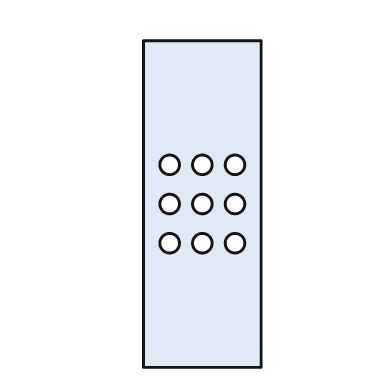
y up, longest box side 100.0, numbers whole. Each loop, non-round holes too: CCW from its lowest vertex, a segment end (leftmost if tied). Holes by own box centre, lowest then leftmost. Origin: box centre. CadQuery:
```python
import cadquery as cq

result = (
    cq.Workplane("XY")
    .moveTo(-18.0, -50.0)
    .lineTo(18.0, -50.0)
    .lineTo(18.0, 50.0)
    .lineTo(-18.0, 50.0)
    .close()
    .moveTo(-10.0, -12.0)
    .circle(3.0)
    .moveTo(0.0, -12.0)
    .circle(3.0)
    .moveTo(10.0, -12.0)
    .circle(3.0)
    .moveTo(-10.0, 0.0)
    .circle(3.0)
    .moveTo(0.0, 0.0)
    .circle(3.0)
    .moveTo(10.0, 0.0)
    .circle(3.0)
    .moveTo(-10.0, 12.0)
    .circle(3.0)
    .moveTo(0.0, 12.0)
    .circle(3.0)
    .moveTo(10.0, 12.0)
    .circle(3.0)
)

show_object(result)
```